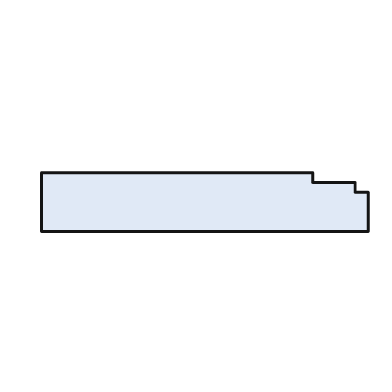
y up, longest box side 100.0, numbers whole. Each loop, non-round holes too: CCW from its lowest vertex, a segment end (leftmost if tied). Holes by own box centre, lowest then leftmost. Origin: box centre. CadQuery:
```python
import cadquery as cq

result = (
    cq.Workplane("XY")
    .moveTo(-50.0, -9.0)
    .lineTo(50.0, -9.0)
    .lineTo(50.0, 3.0)
    .lineTo(46.0, 3.0)
    .lineTo(46.0, 6.0)
    .lineTo(33.0, 6.0)
    .lineTo(33.0, 9.0)
    .lineTo(-50.0, 9.0)
    .close()
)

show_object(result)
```